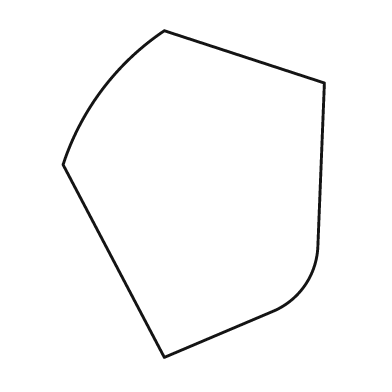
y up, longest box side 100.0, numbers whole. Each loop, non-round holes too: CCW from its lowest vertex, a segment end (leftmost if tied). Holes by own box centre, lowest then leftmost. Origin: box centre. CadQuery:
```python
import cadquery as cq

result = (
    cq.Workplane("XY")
    .moveTo(-9.0, -50.0)
    .lineTo(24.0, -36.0)
    .threePointArc((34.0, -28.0), (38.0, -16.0))
    .lineTo(40.0, 34.0)
    .lineTo(-9.0, 50.0)
    .threePointArc((-28.0, 32.0), (-40.0, 9.0))
    .close()
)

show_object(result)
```